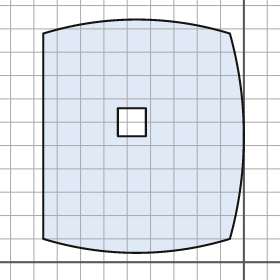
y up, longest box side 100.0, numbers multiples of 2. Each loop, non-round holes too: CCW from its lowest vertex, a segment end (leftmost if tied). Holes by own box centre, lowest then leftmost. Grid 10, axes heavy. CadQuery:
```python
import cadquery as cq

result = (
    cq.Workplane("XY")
    .moveTo(-86.0, 10.0)
    .threePointArc((-46.0, 4.0), (-6.0, 10.0))
    .threePointArc((0.0, 54.0), (-6.0, 98.0))
    .threePointArc((-46.0, 104.0), (-86.0, 98.0))
    .close()
    .moveTo(-54.0, 54.0)
    .lineTo(-42.0, 54.0)
    .lineTo(-42.0, 66.0)
    .lineTo(-54.0, 66.0)
    .close()
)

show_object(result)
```